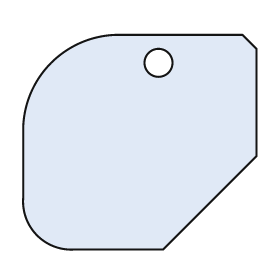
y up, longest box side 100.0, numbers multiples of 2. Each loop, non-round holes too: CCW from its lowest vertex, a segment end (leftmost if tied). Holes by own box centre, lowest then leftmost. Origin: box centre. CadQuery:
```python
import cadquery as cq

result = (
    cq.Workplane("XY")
    .moveTo(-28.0, -46.0)
    .lineTo(10.0, -46.0)
    .lineTo(50.0, -6.0)
    .lineTo(50.0, 40.0)
    .lineTo(44.0, 46.0)
    .lineTo(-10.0, 46.0)
    .threePointArc((-38.0, 34.0), (-50.0, 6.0))
    .lineTo(-50.0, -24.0)
    .threePointArc((-44.0, -40.0), (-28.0, -46.0))
    .close()
    .moveTo(8.0, 34.0)
    .circle(6.0)
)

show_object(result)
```